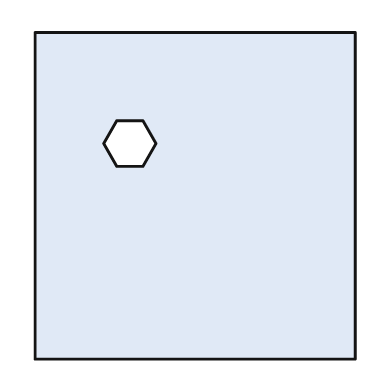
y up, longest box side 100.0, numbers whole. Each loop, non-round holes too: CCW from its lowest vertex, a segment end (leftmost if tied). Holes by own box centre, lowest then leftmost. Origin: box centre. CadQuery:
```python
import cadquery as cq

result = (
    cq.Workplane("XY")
    .moveTo(-49.0, -50.0)
    .lineTo(49.0, -50.0)
    .lineTo(49.0, 50.0)
    .lineTo(-49.0, 50.0)
    .close()
    .moveTo(-24.0, 9.0)
    .lineTo(-16.0, 9.0)
    .lineTo(-12.0, 16.0)
    .lineTo(-16.0, 23.0)
    .lineTo(-24.0, 23.0)
    .lineTo(-28.0, 16.0)
    .close()
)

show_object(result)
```